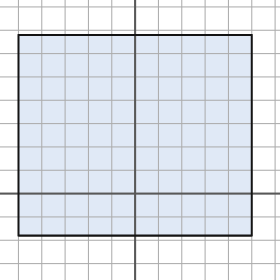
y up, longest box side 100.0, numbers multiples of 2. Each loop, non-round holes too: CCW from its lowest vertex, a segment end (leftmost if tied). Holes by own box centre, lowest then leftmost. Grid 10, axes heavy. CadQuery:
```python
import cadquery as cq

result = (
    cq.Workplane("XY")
    .moveTo(-50.0, -18.0)
    .lineTo(50.0, -18.0)
    .lineTo(50.0, 68.0)
    .lineTo(-50.0, 68.0)
    .close()
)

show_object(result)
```